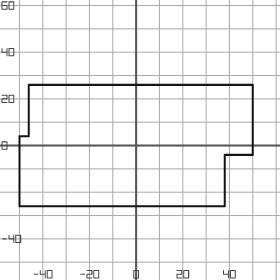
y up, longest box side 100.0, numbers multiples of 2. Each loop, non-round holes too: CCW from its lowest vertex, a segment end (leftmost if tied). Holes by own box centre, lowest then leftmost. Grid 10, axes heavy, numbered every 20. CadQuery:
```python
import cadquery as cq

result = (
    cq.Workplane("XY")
    .moveTo(-50.0, -26.0)
    .lineTo(38.0, -26.0)
    .lineTo(38.0, -4.0)
    .lineTo(50.0, -4.0)
    .lineTo(50.0, 26.0)
    .lineTo(-46.0, 26.0)
    .lineTo(-46.0, 4.0)
    .lineTo(-50.0, 4.0)
    .close()
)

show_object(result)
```